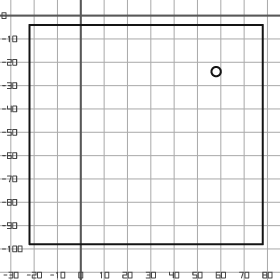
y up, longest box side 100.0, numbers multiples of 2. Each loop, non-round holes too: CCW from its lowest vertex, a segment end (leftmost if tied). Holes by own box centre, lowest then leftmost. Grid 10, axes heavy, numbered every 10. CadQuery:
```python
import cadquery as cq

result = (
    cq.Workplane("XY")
    .moveTo(-22.0, -98.0)
    .lineTo(78.0, -98.0)
    .lineTo(78.0, -4.0)
    .lineTo(-22.0, -4.0)
    .close()
    .moveTo(58.0, -24.0)
    .circle(2.0)
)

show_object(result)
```